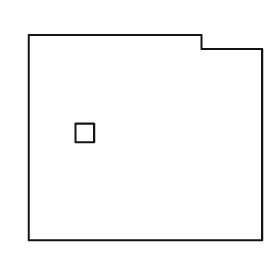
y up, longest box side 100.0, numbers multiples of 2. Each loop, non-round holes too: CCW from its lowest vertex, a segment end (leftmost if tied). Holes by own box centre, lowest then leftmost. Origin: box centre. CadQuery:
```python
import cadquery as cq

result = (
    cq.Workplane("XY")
    .moveTo(-50.0, -44.0)
    .lineTo(50.0, -44.0)
    .lineTo(50.0, 38.0)
    .lineTo(24.0, 38.0)
    .lineTo(24.0, 44.0)
    .lineTo(-50.0, 44.0)
    .close()
    .moveTo(-30.0, -2.0)
    .lineTo(-22.0, -2.0)
    .lineTo(-22.0, 6.0)
    .lineTo(-30.0, 6.0)
    .close()
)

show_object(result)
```